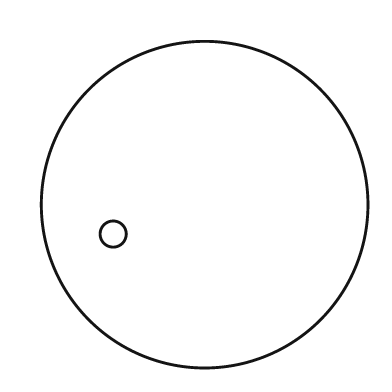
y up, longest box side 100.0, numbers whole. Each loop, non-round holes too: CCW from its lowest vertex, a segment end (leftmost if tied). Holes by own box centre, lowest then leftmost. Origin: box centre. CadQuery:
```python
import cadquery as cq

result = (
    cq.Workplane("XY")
    .moveTo(0.0, 0.0)
    .circle(50.0)
    .moveTo(-28.0, -9.0)
    .circle(4.0)
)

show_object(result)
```